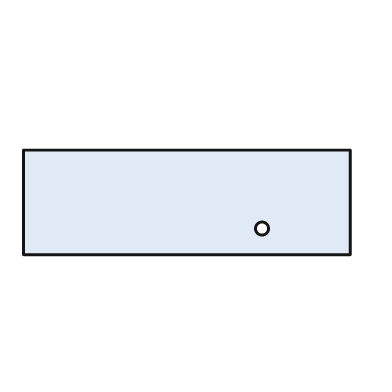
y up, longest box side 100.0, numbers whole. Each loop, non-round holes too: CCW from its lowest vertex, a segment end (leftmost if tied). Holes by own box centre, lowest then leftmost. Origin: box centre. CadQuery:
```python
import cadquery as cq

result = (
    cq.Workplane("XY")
    .moveTo(-50.0, -16.0)
    .lineTo(50.0, -16.0)
    .lineTo(50.0, 16.0)
    .lineTo(-50.0, 16.0)
    .close()
    .moveTo(23.0, -8.0)
    .circle(2.0)
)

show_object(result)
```